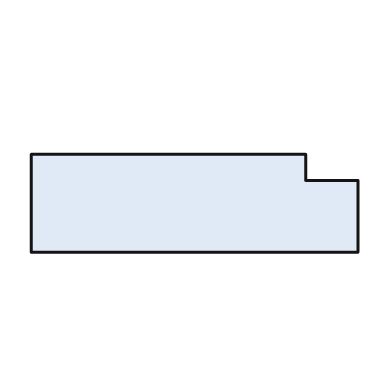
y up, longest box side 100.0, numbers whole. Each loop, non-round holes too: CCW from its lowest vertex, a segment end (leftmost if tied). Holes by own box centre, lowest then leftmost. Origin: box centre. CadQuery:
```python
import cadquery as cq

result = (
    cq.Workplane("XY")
    .moveTo(-50.0, -15.0)
    .lineTo(50.0, -15.0)
    .lineTo(50.0, 7.0)
    .lineTo(34.0, 7.0)
    .lineTo(34.0, 15.0)
    .lineTo(-50.0, 15.0)
    .close()
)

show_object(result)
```